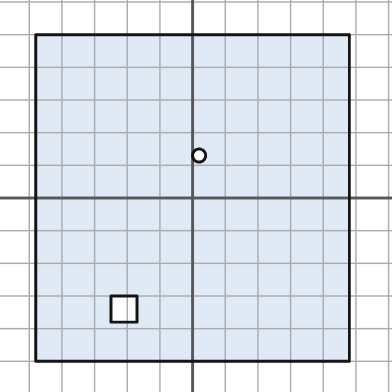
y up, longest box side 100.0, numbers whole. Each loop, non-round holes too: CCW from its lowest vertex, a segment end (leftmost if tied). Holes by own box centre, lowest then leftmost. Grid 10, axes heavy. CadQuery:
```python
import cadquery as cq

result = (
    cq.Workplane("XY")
    .moveTo(-48.0, -50.0)
    .lineTo(48.0, -50.0)
    .lineTo(48.0, 50.0)
    .lineTo(-48.0, 50.0)
    .close()
    .moveTo(-25.0, -38.0)
    .lineTo(-17.0, -38.0)
    .lineTo(-17.0, -30.0)
    .lineTo(-25.0, -30.0)
    .close()
    .moveTo(2.0, 13.0)
    .circle(2.0)
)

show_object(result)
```